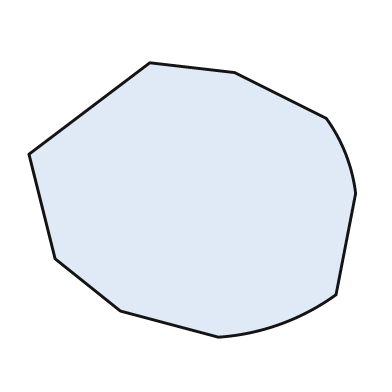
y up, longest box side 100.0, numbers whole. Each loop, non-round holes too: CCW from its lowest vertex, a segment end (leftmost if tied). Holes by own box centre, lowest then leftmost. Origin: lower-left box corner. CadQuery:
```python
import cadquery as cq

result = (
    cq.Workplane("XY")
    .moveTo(58.0, 0.0)
    .threePointArc((77.0, 4.0), (94.0, 13.0))
    .lineTo(100.0, 44.0)
    .threePointArc((97.0, 56.0), (91.0, 67.0))
    .lineTo(63.0, 81.0)
    .lineTo(37.0, 84.0)
    .lineTo(0.0, 56.0)
    .lineTo(8.0, 24.0)
    .lineTo(28.0, 8.0)
    .close()
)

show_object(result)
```